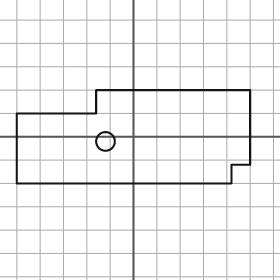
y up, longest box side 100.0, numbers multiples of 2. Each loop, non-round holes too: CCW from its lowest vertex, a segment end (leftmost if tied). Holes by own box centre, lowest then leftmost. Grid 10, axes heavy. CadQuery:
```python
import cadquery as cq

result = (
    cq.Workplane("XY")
    .moveTo(-50.0, -20.0)
    .lineTo(42.0, -20.0)
    .lineTo(42.0, -12.0)
    .lineTo(50.0, -12.0)
    .lineTo(50.0, 20.0)
    .lineTo(-16.0, 20.0)
    .lineTo(-16.0, 10.0)
    .lineTo(-50.0, 10.0)
    .close()
    .moveTo(-12.0, -2.0)
    .circle(4.0)
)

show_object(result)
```